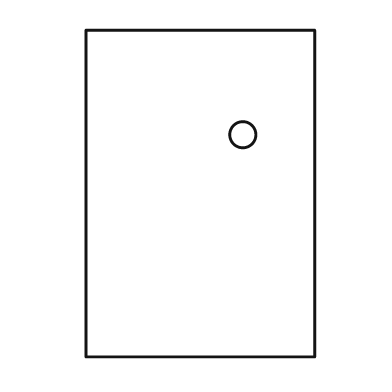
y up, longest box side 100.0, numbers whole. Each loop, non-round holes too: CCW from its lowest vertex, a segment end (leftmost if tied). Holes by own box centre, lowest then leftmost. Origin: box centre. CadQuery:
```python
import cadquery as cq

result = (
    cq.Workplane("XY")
    .moveTo(-35.0, -50.0)
    .lineTo(35.0, -50.0)
    .lineTo(35.0, 50.0)
    .lineTo(-35.0, 50.0)
    .close()
    .moveTo(13.0, 18.0)
    .circle(4.0)
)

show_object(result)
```